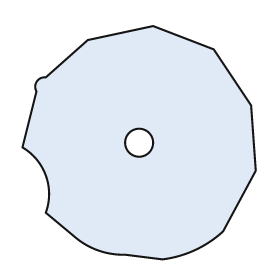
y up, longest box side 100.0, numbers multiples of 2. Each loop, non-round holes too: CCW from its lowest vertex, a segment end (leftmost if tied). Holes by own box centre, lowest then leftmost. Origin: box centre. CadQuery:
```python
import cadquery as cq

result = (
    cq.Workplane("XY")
    .moveTo(10.0, -50.0)
    .threePointArc((24.0, -46.0), (36.0, -38.0))
    .lineTo(50.0, -12.0)
    .lineTo(48.0, 16.0)
    .lineTo(32.0, 40.0)
    .lineTo(6.0, 50.0)
    .lineTo(-22.0, 44.0)
    .lineTo(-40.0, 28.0)
    .threePointArc((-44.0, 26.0), (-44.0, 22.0))
    .lineTo(-50.0, -2.0)
    .threePointArc((-40.0, -14.0), (-40.0, -30.0))
    .lineTo(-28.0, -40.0)
    .threePointArc((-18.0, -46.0), (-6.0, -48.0))
    .close()
    .moveTo(0.0, 0.0)
    .circle(6.0)
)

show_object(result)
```